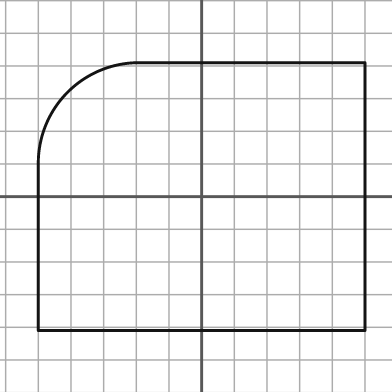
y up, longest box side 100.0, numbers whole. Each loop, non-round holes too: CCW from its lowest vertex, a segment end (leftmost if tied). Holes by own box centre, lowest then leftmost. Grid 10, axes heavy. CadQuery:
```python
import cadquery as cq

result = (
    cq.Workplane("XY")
    .moveTo(-50.0, -41.0)
    .lineTo(50.0, -41.0)
    .lineTo(50.0, 41.0)
    .lineTo(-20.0, 41.0)
    .threePointArc((-41.0, 32.0), (-50.0, 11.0))
    .close()
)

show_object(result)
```